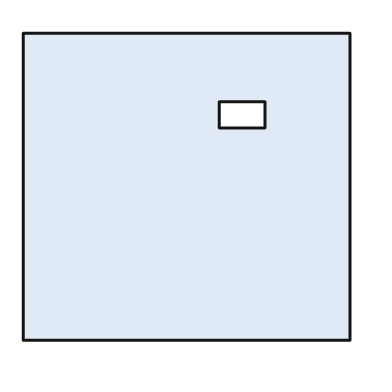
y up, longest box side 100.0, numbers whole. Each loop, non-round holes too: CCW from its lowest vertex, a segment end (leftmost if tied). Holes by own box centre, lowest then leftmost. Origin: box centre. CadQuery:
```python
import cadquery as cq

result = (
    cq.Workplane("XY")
    .moveTo(-50.0, -47.0)
    .lineTo(50.0, -47.0)
    .lineTo(50.0, 47.0)
    .lineTo(-50.0, 47.0)
    .close()
    .moveTo(10.0, 18.0)
    .lineTo(24.0, 18.0)
    .lineTo(24.0, 26.0)
    .lineTo(10.0, 26.0)
    .close()
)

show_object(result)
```